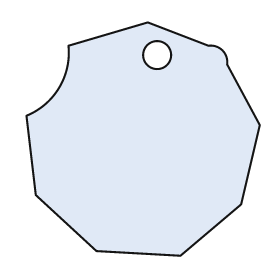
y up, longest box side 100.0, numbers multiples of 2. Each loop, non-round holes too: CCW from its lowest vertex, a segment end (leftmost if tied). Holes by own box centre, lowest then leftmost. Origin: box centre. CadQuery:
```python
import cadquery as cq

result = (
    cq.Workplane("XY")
    .moveTo(16.0, -50.0)
    .lineTo(42.0, -28.0)
    .lineTo(50.0, 6.0)
    .lineTo(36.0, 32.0)
    .threePointArc((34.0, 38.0), (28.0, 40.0))
    .lineTo(2.0, 50.0)
    .lineTo(-32.0, 40.0)
    .threePointArc((-36.0, 22.0), (-50.0, 10.0))
    .lineTo(-46.0, -24.0)
    .lineTo(-20.0, -48.0)
    .close()
    .moveTo(6.0, 36.0)
    .circle(6.0)
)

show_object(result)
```